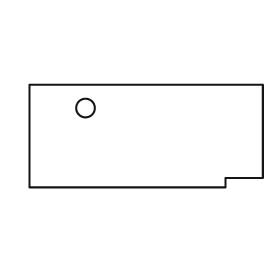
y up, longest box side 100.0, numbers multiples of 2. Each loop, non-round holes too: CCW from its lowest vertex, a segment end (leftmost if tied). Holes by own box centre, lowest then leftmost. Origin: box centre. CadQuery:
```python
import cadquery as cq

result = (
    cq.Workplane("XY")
    .moveTo(-50.0, -22.0)
    .lineTo(34.0, -22.0)
    .lineTo(34.0, -18.0)
    .lineTo(50.0, -18.0)
    .lineTo(50.0, 22.0)
    .lineTo(-50.0, 22.0)
    .close()
    .moveTo(-26.0, 12.0)
    .circle(4.0)
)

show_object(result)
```